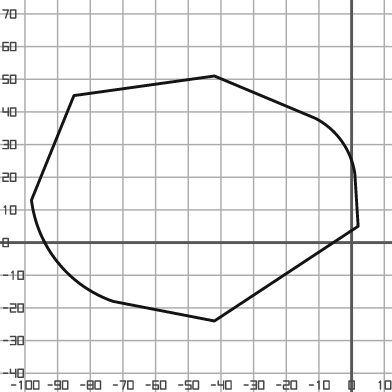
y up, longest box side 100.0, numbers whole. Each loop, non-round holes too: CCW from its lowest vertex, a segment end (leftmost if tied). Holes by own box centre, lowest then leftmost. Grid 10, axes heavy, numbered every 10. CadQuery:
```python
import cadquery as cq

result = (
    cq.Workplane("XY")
    .moveTo(-42.0, -24.0)
    .lineTo(2.0, 5.0)
    .lineTo(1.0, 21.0)
    .threePointArc((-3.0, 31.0), (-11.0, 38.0))
    .lineTo(-42.0, 51.0)
    .lineTo(-85.0, 45.0)
    .lineTo(-98.0, 13.0)
    .threePointArc((-90.0, -6.0), (-73.0, -18.0))
    .close()
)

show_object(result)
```